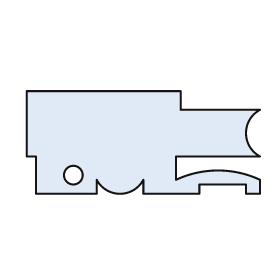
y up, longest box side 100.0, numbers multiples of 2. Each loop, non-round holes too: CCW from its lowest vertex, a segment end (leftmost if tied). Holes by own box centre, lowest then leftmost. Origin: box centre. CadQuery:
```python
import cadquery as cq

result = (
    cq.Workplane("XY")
    .moveTo(-46.0, -22.0)
    .lineTo(-20.0, -22.0)
    .lineTo(-20.0, -16.0)
    .threePointArc((-10.0, -22.0), (0.0, -16.0))
    .lineTo(0.0, -22.0)
    .lineTo(24.0, -22.0)
    .lineTo(24.0, -18.0)
    .lineTo(44.0, -18.0)
    .lineTo(44.0, -22.0)
    .lineTo(50.0, -22.0)
    .lineTo(50.0, -16.0)
    .threePointArc((32.0, -12.0), (14.0, -16.0))
    .lineTo(14.0, -6.0)
    .lineTo(50.0, -6.0)
    .threePointArc((44.0, 4.0), (50.0, 14.0))
    .lineTo(16.0, 14.0)
    .lineTo(16.0, 22.0)
    .lineTo(-50.0, 22.0)
    .lineTo(-50.0, -6.0)
    .lineTo(-46.0, -6.0)
    .close()
    .moveTo(-30.0, -14.0)
    .circle(4.0)
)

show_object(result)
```